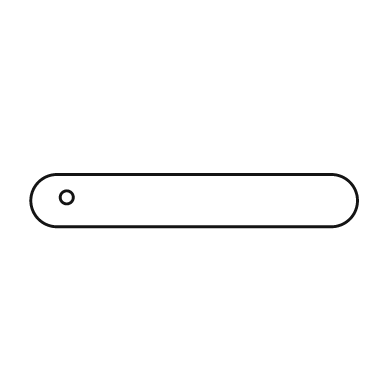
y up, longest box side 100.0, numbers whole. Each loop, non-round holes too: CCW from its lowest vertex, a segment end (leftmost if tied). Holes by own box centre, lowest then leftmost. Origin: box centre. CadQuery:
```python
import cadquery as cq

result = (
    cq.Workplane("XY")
    .moveTo(-42.0, -8.0)
    .lineTo(42.0, -8.0)
    .threePointArc((50.0, 0.0), (42.0, 8.0))
    .lineTo(-42.0, 8.0)
    .threePointArc((-50.0, 0.0), (-42.0, -8.0))
    .close()
    .moveTo(-39.0, 1.0)
    .circle(2.0)
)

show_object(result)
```